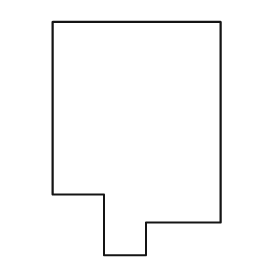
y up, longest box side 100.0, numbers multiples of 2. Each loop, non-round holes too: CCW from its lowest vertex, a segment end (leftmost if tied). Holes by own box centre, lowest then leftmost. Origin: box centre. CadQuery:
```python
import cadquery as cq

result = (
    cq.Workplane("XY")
    .moveTo(-14.0, -50.0)
    .lineTo(4.0, -50.0)
    .lineTo(4.0, -36.0)
    .lineTo(36.0, -36.0)
    .lineTo(36.0, 50.0)
    .lineTo(-36.0, 50.0)
    .lineTo(-36.0, -24.0)
    .lineTo(-14.0, -24.0)
    .close()
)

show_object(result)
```